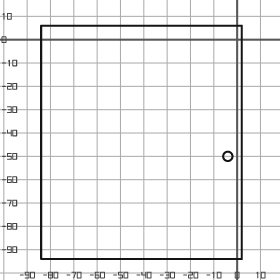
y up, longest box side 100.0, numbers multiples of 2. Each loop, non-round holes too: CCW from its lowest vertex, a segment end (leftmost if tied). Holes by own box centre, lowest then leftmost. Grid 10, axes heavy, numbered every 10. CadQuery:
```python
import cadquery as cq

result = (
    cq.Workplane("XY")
    .moveTo(-84.0, -94.0)
    .lineTo(2.0, -94.0)
    .lineTo(2.0, 6.0)
    .lineTo(-84.0, 6.0)
    .close()
    .moveTo(-4.0, -50.0)
    .circle(2.0)
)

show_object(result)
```